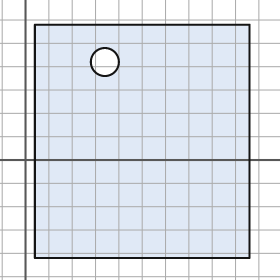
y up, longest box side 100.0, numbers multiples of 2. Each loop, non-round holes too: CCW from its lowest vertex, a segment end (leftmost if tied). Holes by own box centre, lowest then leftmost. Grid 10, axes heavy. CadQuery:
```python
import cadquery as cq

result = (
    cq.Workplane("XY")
    .moveTo(4.0, -42.0)
    .lineTo(96.0, -42.0)
    .lineTo(96.0, 58.0)
    .lineTo(4.0, 58.0)
    .close()
    .moveTo(34.0, 42.0)
    .circle(6.0)
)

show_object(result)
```